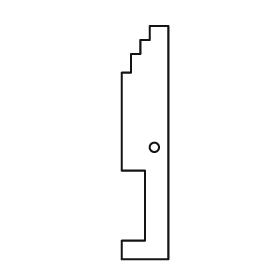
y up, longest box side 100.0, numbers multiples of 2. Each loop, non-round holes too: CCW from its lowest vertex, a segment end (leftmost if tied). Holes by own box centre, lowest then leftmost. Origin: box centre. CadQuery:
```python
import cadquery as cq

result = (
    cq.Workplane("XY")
    .moveTo(-10.0, -50.0)
    .lineTo(10.0, -50.0)
    .lineTo(10.0, 50.0)
    .lineTo(2.0, 50.0)
    .lineTo(2.0, 44.0)
    .lineTo(-2.0, 44.0)
    .lineTo(-2.0, 38.0)
    .lineTo(-6.0, 38.0)
    .lineTo(-6.0, 30.0)
    .lineTo(-10.0, 30.0)
    .lineTo(-10.0, -12.0)
    .lineTo(0.0, -12.0)
    .lineTo(0.0, -42.0)
    .lineTo(-10.0, -42.0)
    .close()
    .moveTo(4.0, -2.0)
    .circle(2.0)
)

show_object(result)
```